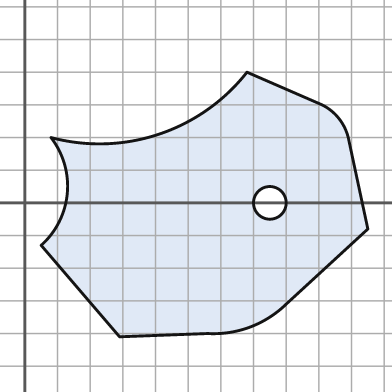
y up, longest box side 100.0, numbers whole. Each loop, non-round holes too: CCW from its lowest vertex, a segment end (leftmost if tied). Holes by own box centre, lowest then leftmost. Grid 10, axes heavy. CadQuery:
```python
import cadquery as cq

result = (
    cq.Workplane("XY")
    .moveTo(29.0, -41.0)
    .lineTo(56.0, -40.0)
    .threePointArc((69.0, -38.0), (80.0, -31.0))
    .lineTo(105.0, -8.0)
    .lineTo(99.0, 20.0)
    .threePointArc((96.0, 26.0), (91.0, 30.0))
    .lineTo(68.0, 40.0)
    .threePointArc((41.0, 21.0), (8.0, 20.0))
    .threePointArc((13.0, 3.0), (5.0, -13.0))
    .close()
    .moveTo(75.0, 0.0)
    .circle(5.0)
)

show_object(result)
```